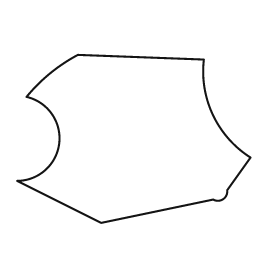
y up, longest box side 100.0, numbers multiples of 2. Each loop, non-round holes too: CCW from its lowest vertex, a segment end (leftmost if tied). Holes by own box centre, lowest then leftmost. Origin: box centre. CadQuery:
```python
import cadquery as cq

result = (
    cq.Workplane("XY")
    .moveTo(-14.0, -36.0)
    .lineTo(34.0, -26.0)
    .threePointArc((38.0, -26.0), (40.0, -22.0))
    .lineTo(50.0, -8.0)
    .threePointArc((34.0, 10.0), (30.0, 34.0))
    .lineTo(-24.0, 36.0)
    .threePointArc((-36.0, 28.0), (-46.0, 18.0))
    .threePointArc((-32.0, -2.0), (-50.0, -18.0))
    .close()
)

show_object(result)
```